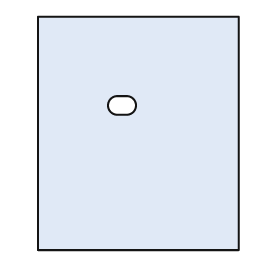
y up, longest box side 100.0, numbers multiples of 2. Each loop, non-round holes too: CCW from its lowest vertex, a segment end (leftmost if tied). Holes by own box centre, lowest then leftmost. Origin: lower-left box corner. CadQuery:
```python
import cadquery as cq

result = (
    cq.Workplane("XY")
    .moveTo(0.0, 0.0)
    .lineTo(86.0, 0.0)
    .lineTo(86.0, 100.0)
    .lineTo(0.0, 100.0)
    .close()
    .moveTo(34.0, 58.0)
    .lineTo(38.0, 58.0)
    .threePointArc((42.0, 62.0), (38.0, 66.0))
    .lineTo(34.0, 66.0)
    .threePointArc((30.0, 62.0), (34.0, 58.0))
    .close()
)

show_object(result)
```